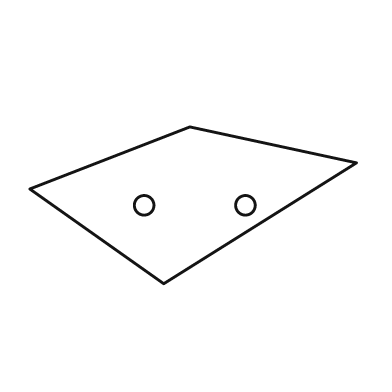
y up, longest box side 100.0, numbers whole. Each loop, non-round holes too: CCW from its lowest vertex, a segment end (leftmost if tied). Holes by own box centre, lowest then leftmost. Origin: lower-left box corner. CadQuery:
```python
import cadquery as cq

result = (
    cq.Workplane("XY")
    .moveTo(41.0, 0.0)
    .lineTo(100.0, 37.0)
    .lineTo(49.0, 48.0)
    .lineTo(0.0, 29.0)
    .close()
    .moveTo(35.0, 24.0)
    .circle(3.0)
    .moveTo(66.0, 24.0)
    .circle(3.0)
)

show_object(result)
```